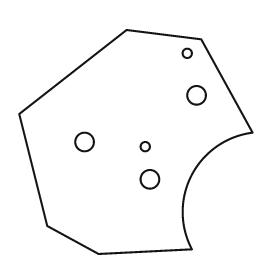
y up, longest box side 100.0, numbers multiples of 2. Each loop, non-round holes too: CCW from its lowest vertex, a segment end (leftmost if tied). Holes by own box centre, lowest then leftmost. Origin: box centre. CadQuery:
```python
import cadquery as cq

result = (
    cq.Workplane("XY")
    .moveTo(-16.0, -48.0)
    .lineTo(24.0, -46.0)
    .threePointArc((24.0, -14.0), (50.0, 4.0))
    .lineTo(28.0, 44.0)
    .lineTo(-4.0, 48.0)
    .lineTo(-50.0, 12.0)
    .lineTo(-38.0, -36.0)
    .close()
    .moveTo(6.0, -16.0)
    .circle(4.0)
    .moveTo(4.0, -2.0)
    .circle(2.0)
    .moveTo(-22.0, 0.0)
    .circle(4.0)
    .moveTo(26.0, 20.0)
    .circle(4.0)
    .moveTo(22.0, 38.0)
    .circle(2.0)
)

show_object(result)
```